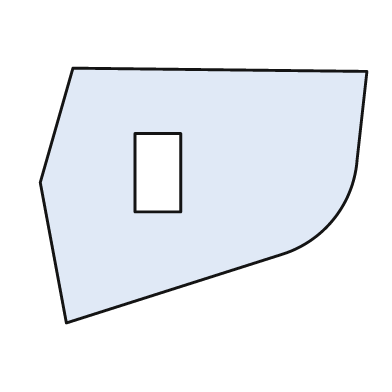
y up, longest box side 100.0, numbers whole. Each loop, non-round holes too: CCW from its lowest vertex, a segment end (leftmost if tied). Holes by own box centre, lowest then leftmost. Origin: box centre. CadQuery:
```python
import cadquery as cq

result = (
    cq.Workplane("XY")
    .moveTo(-42.0, -39.0)
    .lineTo(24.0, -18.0)
    .threePointArc((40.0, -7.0), (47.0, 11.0))
    .lineTo(50.0, 38.0)
    .lineTo(-40.0, 39.0)
    .lineTo(-50.0, 4.0)
    .close()
    .moveTo(-21.0, -5.0)
    .lineTo(-7.0, -5.0)
    .lineTo(-7.0, 19.0)
    .lineTo(-21.0, 19.0)
    .close()
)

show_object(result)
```